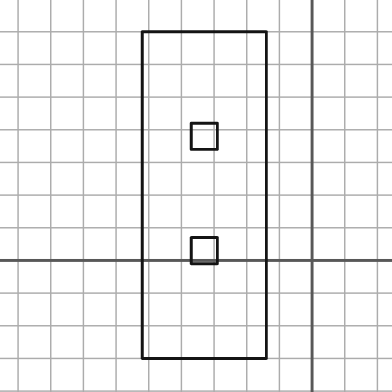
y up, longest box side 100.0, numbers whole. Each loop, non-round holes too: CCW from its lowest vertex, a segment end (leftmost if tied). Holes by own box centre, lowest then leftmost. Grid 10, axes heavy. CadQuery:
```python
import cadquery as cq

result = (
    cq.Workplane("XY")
    .moveTo(-52.0, -30.0)
    .lineTo(-14.0, -30.0)
    .lineTo(-14.0, 70.0)
    .lineTo(-52.0, 70.0)
    .close()
    .moveTo(-37.0, -1.0)
    .lineTo(-29.0, -1.0)
    .lineTo(-29.0, 7.0)
    .lineTo(-37.0, 7.0)
    .close()
    .moveTo(-37.0, 34.0)
    .lineTo(-29.0, 34.0)
    .lineTo(-29.0, 42.0)
    .lineTo(-37.0, 42.0)
    .close()
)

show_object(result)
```